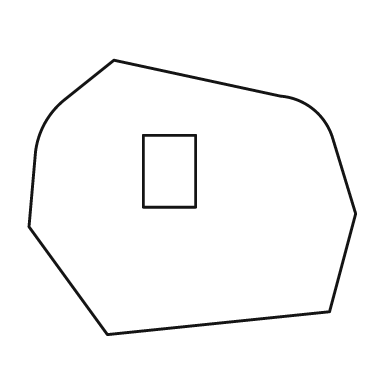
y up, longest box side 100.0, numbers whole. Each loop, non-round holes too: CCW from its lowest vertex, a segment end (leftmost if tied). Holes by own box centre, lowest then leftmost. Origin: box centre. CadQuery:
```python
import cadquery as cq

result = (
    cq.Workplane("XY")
    .moveTo(-26.0, -42.0)
    .lineTo(42.0, -35.0)
    .lineTo(50.0, -5.0)
    .lineTo(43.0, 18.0)
    .threePointArc((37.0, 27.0), (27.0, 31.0))
    .lineTo(-24.0, 42.0)
    .lineTo(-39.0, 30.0)
    .threePointArc((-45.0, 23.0), (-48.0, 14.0))
    .lineTo(-50.0, -9.0)
    .close()
    .moveTo(-15.0, -3.0)
    .lineTo(1.0, -3.0)
    .lineTo(1.0, 19.0)
    .lineTo(-15.0, 19.0)
    .close()
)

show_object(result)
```